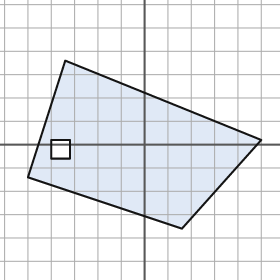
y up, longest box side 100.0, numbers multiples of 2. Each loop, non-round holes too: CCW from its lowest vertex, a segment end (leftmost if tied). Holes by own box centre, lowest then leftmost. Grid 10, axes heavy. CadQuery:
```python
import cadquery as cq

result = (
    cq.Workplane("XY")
    .moveTo(16.0, -36.0)
    .lineTo(50.0, 2.0)
    .lineTo(-34.0, 36.0)
    .lineTo(-50.0, -14.0)
    .close()
    .moveTo(-40.0, -6.0)
    .lineTo(-32.0, -6.0)
    .lineTo(-32.0, 2.0)
    .lineTo(-40.0, 2.0)
    .close()
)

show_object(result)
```